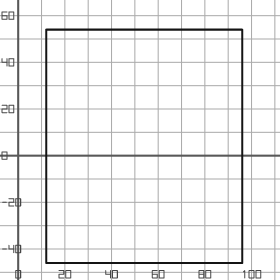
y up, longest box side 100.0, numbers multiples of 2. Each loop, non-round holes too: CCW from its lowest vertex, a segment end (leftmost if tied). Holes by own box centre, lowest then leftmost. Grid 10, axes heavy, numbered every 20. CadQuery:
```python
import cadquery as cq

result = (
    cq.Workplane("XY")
    .moveTo(12.0, -46.0)
    .lineTo(96.0, -46.0)
    .lineTo(96.0, 54.0)
    .lineTo(12.0, 54.0)
    .close()
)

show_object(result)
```